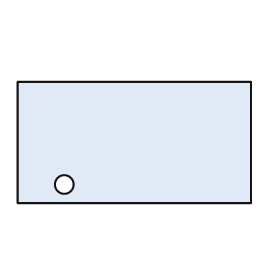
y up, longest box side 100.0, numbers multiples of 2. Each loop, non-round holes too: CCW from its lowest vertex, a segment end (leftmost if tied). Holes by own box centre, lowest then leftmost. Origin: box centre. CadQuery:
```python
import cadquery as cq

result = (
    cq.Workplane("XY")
    .moveTo(-50.0, -26.0)
    .lineTo(50.0, -26.0)
    .lineTo(50.0, 26.0)
    .lineTo(-50.0, 26.0)
    .close()
    .moveTo(-30.0, -18.0)
    .circle(4.0)
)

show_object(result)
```